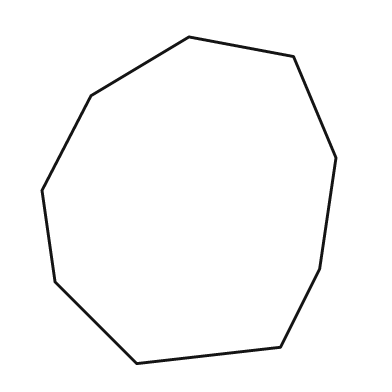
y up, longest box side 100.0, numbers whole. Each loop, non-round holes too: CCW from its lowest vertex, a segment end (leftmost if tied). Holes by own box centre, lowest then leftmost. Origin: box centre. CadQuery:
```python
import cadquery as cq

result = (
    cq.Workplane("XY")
    .moveTo(-16.0, -50.0)
    .lineTo(28.0, -45.0)
    .lineTo(40.0, -21.0)
    .lineTo(45.0, 13.0)
    .lineTo(32.0, 44.0)
    .lineTo(0.0, 50.0)
    .lineTo(-30.0, 32.0)
    .lineTo(-45.0, 3.0)
    .lineTo(-41.0, -25.0)
    .close()
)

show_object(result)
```